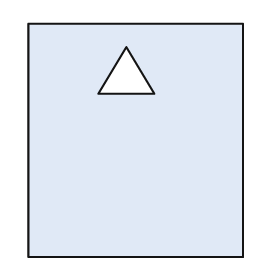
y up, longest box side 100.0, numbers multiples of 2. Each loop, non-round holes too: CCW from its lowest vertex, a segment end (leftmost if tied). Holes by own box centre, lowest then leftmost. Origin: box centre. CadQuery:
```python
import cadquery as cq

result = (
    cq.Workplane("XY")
    .moveTo(-46.0, -50.0)
    .lineTo(46.0, -50.0)
    .lineTo(46.0, 50.0)
    .lineTo(-46.0, 50.0)
    .close()
    .moveTo(-16.0, 20.0)
    .lineTo(8.0, 20.0)
    .lineTo(-4.0, 40.0)
    .close()
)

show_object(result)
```